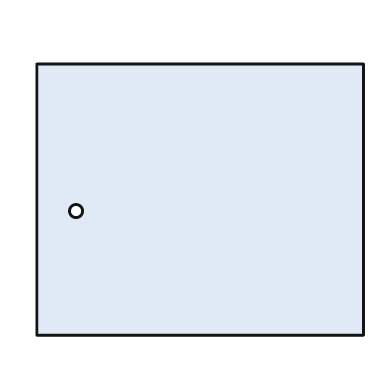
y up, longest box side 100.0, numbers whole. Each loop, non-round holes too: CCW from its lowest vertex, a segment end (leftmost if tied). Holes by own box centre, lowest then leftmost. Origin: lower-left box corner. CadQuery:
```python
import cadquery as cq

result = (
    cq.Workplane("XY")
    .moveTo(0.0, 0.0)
    .lineTo(100.0, 0.0)
    .lineTo(100.0, 83.0)
    .lineTo(0.0, 83.0)
    .close()
    .moveTo(12.0, 38.0)
    .circle(2.0)
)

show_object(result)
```